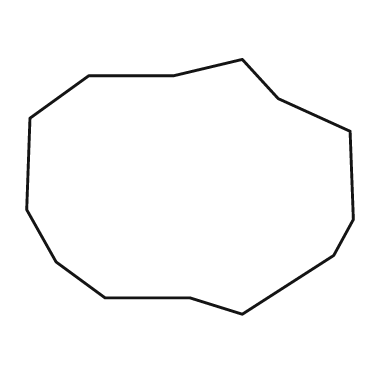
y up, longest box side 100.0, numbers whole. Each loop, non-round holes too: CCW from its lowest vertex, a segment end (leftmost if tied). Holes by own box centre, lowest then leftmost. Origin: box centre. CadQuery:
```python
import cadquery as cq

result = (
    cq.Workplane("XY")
    .moveTo(16.0, -39.0)
    .lineTo(44.0, -21.0)
    .lineTo(50.0, -10.0)
    .lineTo(49.0, 17.0)
    .lineTo(27.0, 27.0)
    .lineTo(16.0, 39.0)
    .lineTo(-5.0, 34.0)
    .lineTo(-31.0, 34.0)
    .lineTo(-49.0, 21.0)
    .lineTo(-50.0, -7.0)
    .lineTo(-41.0, -23.0)
    .lineTo(-26.0, -34.0)
    .lineTo(0.0, -34.0)
    .close()
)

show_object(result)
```